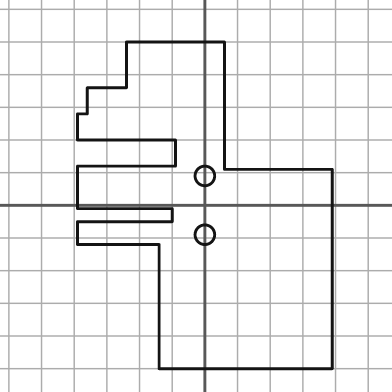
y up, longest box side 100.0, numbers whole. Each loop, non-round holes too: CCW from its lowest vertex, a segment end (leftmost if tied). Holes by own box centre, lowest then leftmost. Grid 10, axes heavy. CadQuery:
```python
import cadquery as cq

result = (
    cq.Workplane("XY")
    .moveTo(-14.0, -50.0)
    .lineTo(39.0, -50.0)
    .lineTo(39.0, 11.0)
    .lineTo(6.0, 11.0)
    .lineTo(6.0, 50.0)
    .lineTo(-24.0, 50.0)
    .lineTo(-24.0, 36.0)
    .lineTo(-36.0, 36.0)
    .lineTo(-36.0, 28.0)
    .lineTo(-39.0, 28.0)
    .lineTo(-39.0, 20.0)
    .lineTo(-9.0, 20.0)
    .lineTo(-9.0, 12.0)
    .lineTo(-39.0, 12.0)
    .lineTo(-39.0, -1.0)
    .lineTo(-10.0, -1.0)
    .lineTo(-10.0, -5.0)
    .lineTo(-39.0, -5.0)
    .lineTo(-39.0, -12.0)
    .lineTo(-14.0, -12.0)
    .close()
    .moveTo(0.0, -9.0)
    .circle(3.0)
    .moveTo(0.0, 9.0)
    .circle(3.0)
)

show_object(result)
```